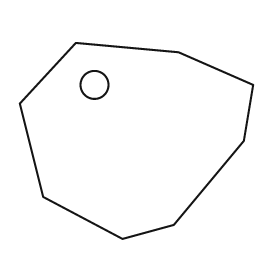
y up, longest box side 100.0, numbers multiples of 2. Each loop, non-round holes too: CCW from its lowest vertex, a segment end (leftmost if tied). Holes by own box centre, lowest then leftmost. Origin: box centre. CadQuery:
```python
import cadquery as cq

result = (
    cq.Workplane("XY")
    .moveTo(-6.0, -42.0)
    .lineTo(16.0, -36.0)
    .lineTo(46.0, 0.0)
    .lineTo(50.0, 24.0)
    .lineTo(18.0, 38.0)
    .lineTo(-26.0, 42.0)
    .lineTo(-50.0, 16.0)
    .lineTo(-40.0, -24.0)
    .close()
    .moveTo(-18.0, 24.0)
    .circle(6.0)
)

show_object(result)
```